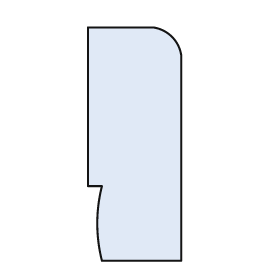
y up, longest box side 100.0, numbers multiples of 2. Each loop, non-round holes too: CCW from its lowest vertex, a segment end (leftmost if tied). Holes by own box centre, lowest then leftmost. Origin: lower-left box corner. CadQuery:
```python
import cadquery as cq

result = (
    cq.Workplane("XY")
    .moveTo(6.0, 0.0)
    .lineTo(40.0, 0.0)
    .lineTo(40.0, 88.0)
    .threePointArc((36.0, 96.0), (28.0, 100.0))
    .lineTo(0.0, 100.0)
    .lineTo(0.0, 32.0)
    .lineTo(6.0, 32.0)
    .threePointArc((4.0, 16.0), (6.0, 0.0))
    .close()
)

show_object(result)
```